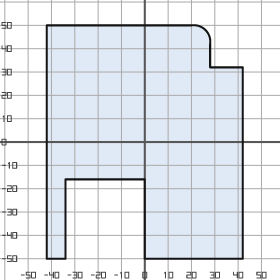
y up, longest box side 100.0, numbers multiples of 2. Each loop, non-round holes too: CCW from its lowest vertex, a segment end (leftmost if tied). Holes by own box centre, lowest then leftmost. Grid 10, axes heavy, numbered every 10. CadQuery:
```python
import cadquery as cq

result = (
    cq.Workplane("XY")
    .moveTo(-42.0, -50.0)
    .lineTo(-34.0, -50.0)
    .lineTo(-34.0, -16.0)
    .lineTo(0.0, -16.0)
    .lineTo(0.0, -50.0)
    .lineTo(42.0, -50.0)
    .lineTo(42.0, 32.0)
    .lineTo(28.0, 32.0)
    .lineTo(28.0, 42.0)
    .threePointArc((26.0, 48.0), (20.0, 50.0))
    .lineTo(-42.0, 50.0)
    .close()
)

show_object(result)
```